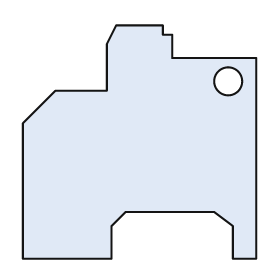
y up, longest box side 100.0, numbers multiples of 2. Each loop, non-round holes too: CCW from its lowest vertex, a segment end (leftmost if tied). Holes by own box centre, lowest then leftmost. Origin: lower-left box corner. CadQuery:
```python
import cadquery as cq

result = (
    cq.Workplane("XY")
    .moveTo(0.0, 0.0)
    .lineTo(38.0, 0.0)
    .lineTo(38.0, 14.0)
    .lineTo(44.0, 20.0)
    .lineTo(82.0, 20.0)
    .lineTo(90.0, 14.0)
    .lineTo(90.0, 0.0)
    .lineTo(100.0, 0.0)
    .lineTo(100.0, 86.0)
    .lineTo(64.0, 86.0)
    .lineTo(64.0, 96.0)
    .lineTo(60.0, 96.0)
    .lineTo(60.0, 100.0)
    .lineTo(40.0, 100.0)
    .lineTo(36.0, 92.0)
    .lineTo(36.0, 72.0)
    .lineTo(14.0, 72.0)
    .lineTo(0.0, 58.0)
    .close()
    .moveTo(88.0, 76.0)
    .circle(6.0)
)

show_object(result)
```